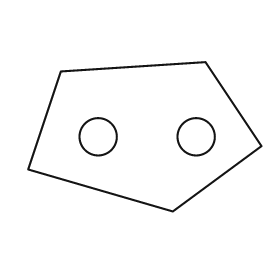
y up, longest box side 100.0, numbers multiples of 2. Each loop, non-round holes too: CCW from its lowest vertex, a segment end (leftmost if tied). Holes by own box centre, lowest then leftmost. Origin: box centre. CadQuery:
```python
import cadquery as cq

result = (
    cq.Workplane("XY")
    .moveTo(12.0, -32.0)
    .lineTo(50.0, -4.0)
    .lineTo(26.0, 32.0)
    .lineTo(-36.0, 28.0)
    .lineTo(-50.0, -14.0)
    .close()
    .moveTo(-20.0, 0.0)
    .circle(8.0)
    .moveTo(22.0, 0.0)
    .circle(8.0)
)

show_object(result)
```